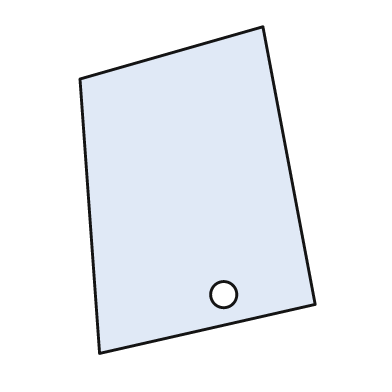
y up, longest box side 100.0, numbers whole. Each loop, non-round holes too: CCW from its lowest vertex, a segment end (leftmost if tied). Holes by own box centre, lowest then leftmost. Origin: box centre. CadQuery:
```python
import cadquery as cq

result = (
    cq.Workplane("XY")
    .moveTo(-30.0, -50.0)
    .lineTo(36.0, -35.0)
    .lineTo(20.0, 50.0)
    .lineTo(-36.0, 34.0)
    .close()
    .moveTo(8.0, -32.0)
    .circle(4.0)
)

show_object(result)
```